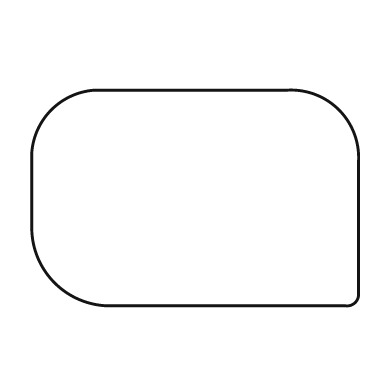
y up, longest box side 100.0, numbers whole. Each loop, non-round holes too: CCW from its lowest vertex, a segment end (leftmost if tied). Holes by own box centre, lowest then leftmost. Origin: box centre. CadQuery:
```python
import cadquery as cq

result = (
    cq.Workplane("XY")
    .moveTo(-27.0, -33.0)
    .lineTo(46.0, -33.0)
    .threePointArc((49.0, -32.0), (50.0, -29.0))
    .lineTo(50.0, 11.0)
    .threePointArc((44.0, 27.0), (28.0, 33.0))
    .lineTo(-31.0, 33.0)
    .threePointArc((-44.0, 27.0), (-50.0, 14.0))
    .lineTo(-50.0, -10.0)
    .threePointArc((-43.0, -26.0), (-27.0, -33.0))
    .close()
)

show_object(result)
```